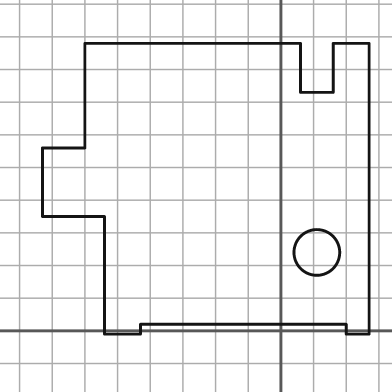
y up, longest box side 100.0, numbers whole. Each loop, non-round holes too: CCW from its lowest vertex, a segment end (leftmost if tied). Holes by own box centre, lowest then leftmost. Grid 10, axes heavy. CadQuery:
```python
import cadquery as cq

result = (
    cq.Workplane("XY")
    .moveTo(-54.0, -1.0)
    .lineTo(-43.0, -1.0)
    .lineTo(-43.0, 2.0)
    .lineTo(20.0, 2.0)
    .lineTo(20.0, -1.0)
    .lineTo(27.0, -1.0)
    .lineTo(27.0, 88.0)
    .lineTo(16.0, 88.0)
    .lineTo(16.0, 73.0)
    .lineTo(6.0, 73.0)
    .lineTo(6.0, 88.0)
    .lineTo(-60.0, 88.0)
    .lineTo(-60.0, 56.0)
    .lineTo(-73.0, 56.0)
    .lineTo(-73.0, 35.0)
    .lineTo(-54.0, 35.0)
    .close()
    .moveTo(11.0, 24.0)
    .circle(7.0)
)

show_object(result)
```